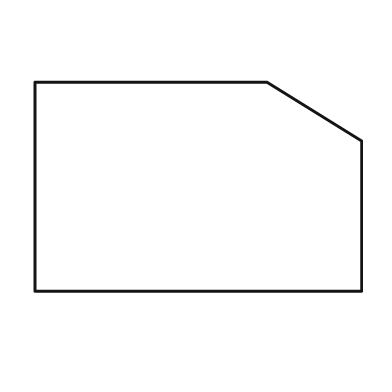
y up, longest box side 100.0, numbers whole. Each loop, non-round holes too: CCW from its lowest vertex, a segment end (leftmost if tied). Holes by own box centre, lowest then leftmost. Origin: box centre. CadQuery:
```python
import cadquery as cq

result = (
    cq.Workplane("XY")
    .moveTo(-50.0, -32.0)
    .lineTo(50.0, -32.0)
    .lineTo(50.0, 14.0)
    .lineTo(21.0, 32.0)
    .lineTo(-50.0, 32.0)
    .close()
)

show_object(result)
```